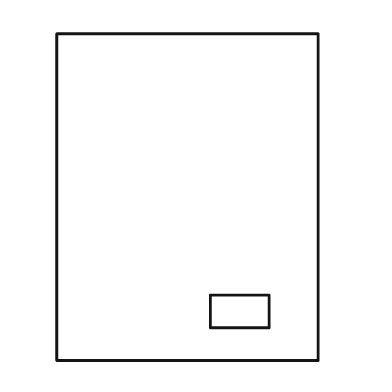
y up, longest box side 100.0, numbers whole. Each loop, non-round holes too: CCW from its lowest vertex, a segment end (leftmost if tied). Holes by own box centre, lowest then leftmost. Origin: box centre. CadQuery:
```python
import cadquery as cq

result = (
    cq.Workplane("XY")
    .moveTo(-40.0, -50.0)
    .lineTo(40.0, -50.0)
    .lineTo(40.0, 50.0)
    .lineTo(-40.0, 50.0)
    .close()
    .moveTo(7.0, -40.0)
    .lineTo(25.0, -40.0)
    .lineTo(25.0, -30.0)
    .lineTo(7.0, -30.0)
    .close()
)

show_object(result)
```